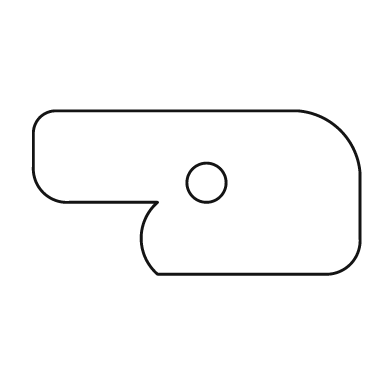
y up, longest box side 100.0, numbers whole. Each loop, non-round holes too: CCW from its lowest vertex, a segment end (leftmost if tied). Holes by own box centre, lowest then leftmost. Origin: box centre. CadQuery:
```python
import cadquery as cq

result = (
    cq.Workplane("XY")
    .moveTo(-12.0, -25.0)
    .lineTo(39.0, -25.0)
    .threePointArc((47.0, -22.0), (50.0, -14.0))
    .lineTo(50.0, 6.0)
    .threePointArc((44.0, 19.0), (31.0, 25.0))
    .lineTo(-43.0, 25.0)
    .threePointArc((-48.0, 23.0), (-50.0, 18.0))
    .lineTo(-50.0, 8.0)
    .threePointArc((-47.0, 0.0), (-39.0, -3.0))
    .lineTo(-12.0, -3.0)
    .threePointArc((-17.0, -14.0), (-12.0, -25.0))
    .close()
    .moveTo(3.0, 3.0)
    .circle(6.0)
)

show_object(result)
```